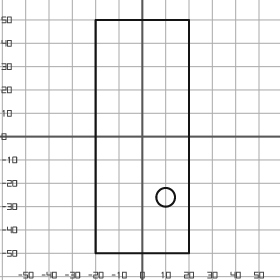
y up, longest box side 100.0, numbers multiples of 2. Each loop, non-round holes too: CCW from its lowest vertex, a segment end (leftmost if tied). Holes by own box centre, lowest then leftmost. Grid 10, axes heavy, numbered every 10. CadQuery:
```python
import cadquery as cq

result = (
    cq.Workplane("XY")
    .moveTo(-20.0, -50.0)
    .lineTo(20.0, -50.0)
    .lineTo(20.0, 50.0)
    .lineTo(-20.0, 50.0)
    .close()
    .moveTo(10.0, -26.0)
    .circle(4.0)
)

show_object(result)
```